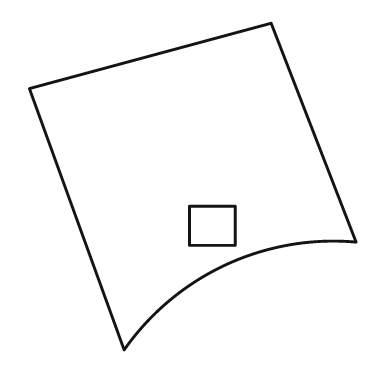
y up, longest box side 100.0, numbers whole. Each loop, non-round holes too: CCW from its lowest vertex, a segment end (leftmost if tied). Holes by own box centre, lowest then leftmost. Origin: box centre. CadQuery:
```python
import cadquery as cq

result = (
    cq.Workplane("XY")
    .moveTo(-21.0, -50.0)
    .threePointArc((10.0, -24.0), (50.0, -17.0))
    .lineTo(24.0, 50.0)
    .lineTo(-50.0, 30.0)
    .close()
    .moveTo(-1.0, -18.0)
    .lineTo(13.0, -18.0)
    .lineTo(13.0, -6.0)
    .lineTo(-1.0, -6.0)
    .close()
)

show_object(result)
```